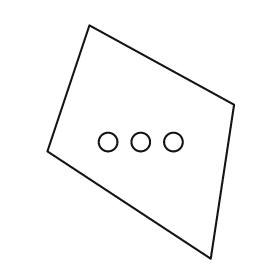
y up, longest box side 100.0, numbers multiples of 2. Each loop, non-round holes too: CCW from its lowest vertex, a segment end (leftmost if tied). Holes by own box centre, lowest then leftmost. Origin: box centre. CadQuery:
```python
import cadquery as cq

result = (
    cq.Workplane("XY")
    .moveTo(30.0, -50.0)
    .lineTo(40.0, 16.0)
    .lineTo(-22.0, 50.0)
    .lineTo(-40.0, -4.0)
    .close()
    .moveTo(-14.0, 0.0)
    .circle(4.0)
    .moveTo(0.0, 0.0)
    .circle(4.0)
    .moveTo(14.0, 0.0)
    .circle(4.0)
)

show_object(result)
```